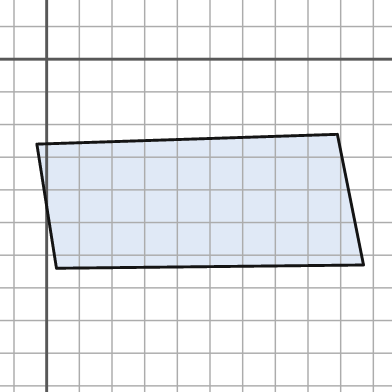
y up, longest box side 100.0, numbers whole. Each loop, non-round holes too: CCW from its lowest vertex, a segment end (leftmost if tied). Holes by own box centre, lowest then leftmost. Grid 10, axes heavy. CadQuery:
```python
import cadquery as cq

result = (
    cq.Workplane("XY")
    .moveTo(3.0, -64.0)
    .lineTo(97.0, -63.0)
    .lineTo(89.0, -23.0)
    .lineTo(-3.0, -26.0)
    .close()
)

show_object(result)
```